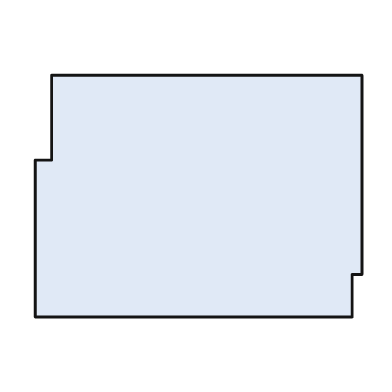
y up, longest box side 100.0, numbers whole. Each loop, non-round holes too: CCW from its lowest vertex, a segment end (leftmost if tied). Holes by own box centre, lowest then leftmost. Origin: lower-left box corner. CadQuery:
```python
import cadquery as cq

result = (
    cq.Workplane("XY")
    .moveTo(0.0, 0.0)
    .lineTo(97.0, 0.0)
    .lineTo(97.0, 13.0)
    .lineTo(100.0, 13.0)
    .lineTo(100.0, 74.0)
    .lineTo(5.0, 74.0)
    .lineTo(5.0, 48.0)
    .lineTo(0.0, 48.0)
    .close()
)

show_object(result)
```